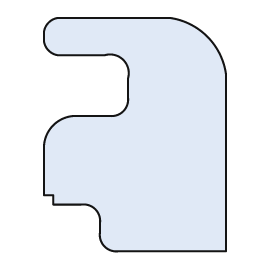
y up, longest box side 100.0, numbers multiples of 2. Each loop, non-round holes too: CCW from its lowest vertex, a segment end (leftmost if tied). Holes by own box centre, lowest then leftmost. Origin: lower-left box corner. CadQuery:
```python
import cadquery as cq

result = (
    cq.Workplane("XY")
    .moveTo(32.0, 0.0)
    .lineTo(78.0, 0.0)
    .lineTo(78.0, 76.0)
    .threePointArc((70.0, 92.0), (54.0, 100.0))
    .lineTo(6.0, 100.0)
    .threePointArc((2.0, 98.0), (0.0, 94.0))
    .lineTo(0.0, 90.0)
    .threePointArc((2.0, 86.0), (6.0, 84.0))
    .lineTo(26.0, 84.0)
    .threePointArc((34.0, 82.0), (36.0, 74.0))
    .lineTo(36.0, 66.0)
    .threePointArc((34.0, 60.0), (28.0, 58.0))
    .lineTo(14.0, 58.0)
    .threePointArc((4.0, 54.0), (0.0, 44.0))
    .lineTo(0.0, 24.0)
    .lineTo(4.0, 24.0)
    .lineTo(4.0, 20.0)
    .lineTo(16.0, 20.0)
    .threePointArc((22.0, 18.0), (24.0, 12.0))
    .lineTo(24.0, 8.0)
    .threePointArc((26.0, 2.0), (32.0, 0.0))
    .close()
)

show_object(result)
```